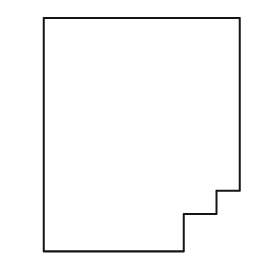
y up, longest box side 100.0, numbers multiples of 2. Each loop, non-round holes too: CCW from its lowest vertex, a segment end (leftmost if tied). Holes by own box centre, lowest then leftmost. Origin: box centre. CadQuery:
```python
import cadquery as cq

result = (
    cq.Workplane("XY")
    .moveTo(-42.0, -50.0)
    .lineTo(18.0, -50.0)
    .lineTo(18.0, -34.0)
    .lineTo(32.0, -34.0)
    .lineTo(32.0, -24.0)
    .lineTo(42.0, -24.0)
    .lineTo(42.0, 50.0)
    .lineTo(-42.0, 50.0)
    .close()
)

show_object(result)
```